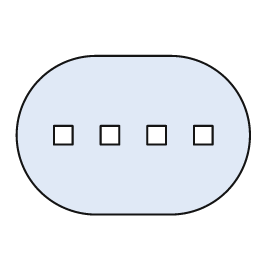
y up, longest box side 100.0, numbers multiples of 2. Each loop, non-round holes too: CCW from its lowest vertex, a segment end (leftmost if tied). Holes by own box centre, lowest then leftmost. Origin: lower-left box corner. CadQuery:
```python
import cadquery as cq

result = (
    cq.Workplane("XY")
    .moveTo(34.0, 0.0)
    .lineTo(66.0, 0.0)
    .threePointArc((100.0, 34.0), (66.0, 68.0))
    .lineTo(34.0, 68.0)
    .threePointArc((0.0, 34.0), (34.0, 0.0))
    .close()
    .moveTo(16.0, 30.0)
    .lineTo(24.0, 30.0)
    .lineTo(24.0, 38.0)
    .lineTo(16.0, 38.0)
    .close()
    .moveTo(36.0, 30.0)
    .lineTo(44.0, 30.0)
    .lineTo(44.0, 38.0)
    .lineTo(36.0, 38.0)
    .close()
    .moveTo(56.0, 30.0)
    .lineTo(64.0, 30.0)
    .lineTo(64.0, 38.0)
    .lineTo(56.0, 38.0)
    .close()
    .moveTo(76.0, 30.0)
    .lineTo(84.0, 30.0)
    .lineTo(84.0, 38.0)
    .lineTo(76.0, 38.0)
    .close()
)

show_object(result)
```